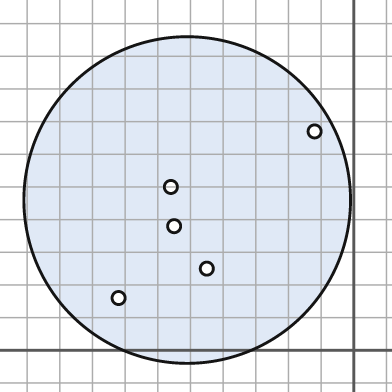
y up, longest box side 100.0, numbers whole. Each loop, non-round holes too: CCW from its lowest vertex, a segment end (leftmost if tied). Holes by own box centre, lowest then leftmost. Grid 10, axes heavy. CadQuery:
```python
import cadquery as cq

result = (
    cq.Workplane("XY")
    .moveTo(-51.0, 46.0)
    .circle(50.0)
    .moveTo(-72.0, 16.0)
    .circle(2.0)
    .moveTo(-45.0, 25.0)
    .circle(2.0)
    .moveTo(-55.0, 38.0)
    .circle(2.0)
    .moveTo(-56.0, 50.0)
    .circle(2.0)
    .moveTo(-12.0, 67.0)
    .circle(2.0)
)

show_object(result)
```